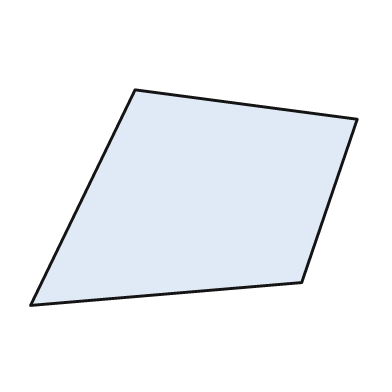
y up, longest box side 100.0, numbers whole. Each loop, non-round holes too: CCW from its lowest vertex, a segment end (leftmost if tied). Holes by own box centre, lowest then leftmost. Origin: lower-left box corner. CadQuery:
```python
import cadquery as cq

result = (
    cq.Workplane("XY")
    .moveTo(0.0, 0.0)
    .lineTo(83.0, 7.0)
    .lineTo(100.0, 57.0)
    .lineTo(32.0, 66.0)
    .close()
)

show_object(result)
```